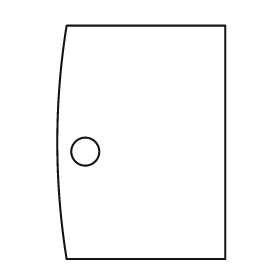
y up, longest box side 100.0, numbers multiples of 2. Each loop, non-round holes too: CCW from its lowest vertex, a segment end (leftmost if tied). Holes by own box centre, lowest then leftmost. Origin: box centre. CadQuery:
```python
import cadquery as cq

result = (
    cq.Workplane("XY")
    .moveTo(-32.0, -50.0)
    .lineTo(36.0, -50.0)
    .lineTo(36.0, 50.0)
    .lineTo(-32.0, 50.0)
    .threePointArc((-36.0, 0.0), (-32.0, -50.0))
    .close()
    .moveTo(-24.0, -4.0)
    .circle(6.0)
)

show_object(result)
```